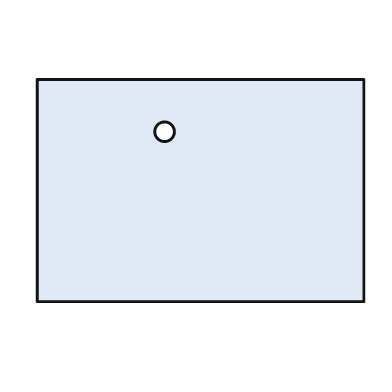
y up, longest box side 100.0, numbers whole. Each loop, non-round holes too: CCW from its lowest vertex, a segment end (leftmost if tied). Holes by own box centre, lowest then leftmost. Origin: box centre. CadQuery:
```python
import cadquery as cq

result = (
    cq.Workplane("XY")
    .moveTo(-50.0, -34.0)
    .lineTo(50.0, -34.0)
    .lineTo(50.0, 34.0)
    .lineTo(-50.0, 34.0)
    .close()
    .moveTo(-11.0, 18.0)
    .circle(3.0)
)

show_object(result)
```